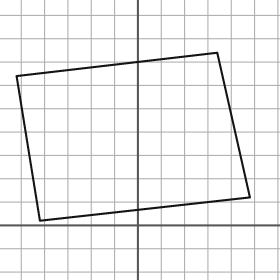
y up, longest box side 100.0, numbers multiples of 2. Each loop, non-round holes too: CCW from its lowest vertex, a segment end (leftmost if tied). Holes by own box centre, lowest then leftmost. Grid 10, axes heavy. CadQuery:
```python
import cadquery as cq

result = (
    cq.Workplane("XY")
    .moveTo(-42.0, 2.0)
    .lineTo(48.0, 12.0)
    .lineTo(34.0, 74.0)
    .lineTo(-52.0, 64.0)
    .close()
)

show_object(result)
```